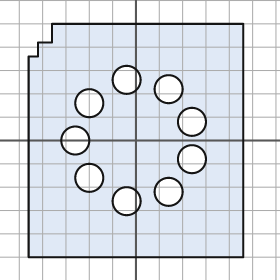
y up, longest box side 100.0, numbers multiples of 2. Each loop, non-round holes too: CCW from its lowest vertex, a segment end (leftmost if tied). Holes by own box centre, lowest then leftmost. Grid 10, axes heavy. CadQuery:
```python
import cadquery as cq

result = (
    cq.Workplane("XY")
    .moveTo(-46.0, -50.0)
    .lineTo(46.0, -50.0)
    .lineTo(46.0, 50.0)
    .lineTo(-36.0, 50.0)
    .lineTo(-36.0, 42.0)
    .lineTo(-42.0, 42.0)
    .lineTo(-42.0, 36.0)
    .lineTo(-46.0, 36.0)
    .close()
    .moveTo(-4.0, -26.0)
    .circle(6.0)
    .moveTo(14.0, -22.0)
    .circle(6.0)
    .moveTo(-20.0, -16.0)
    .circle(6.0)
    .moveTo(24.0, -8.0)
    .circle(6.0)
    .moveTo(-26.0, 0.0)
    .circle(6.0)
    .moveTo(24.0, 8.0)
    .circle(6.0)
    .moveTo(-20.0, 16.0)
    .circle(6.0)
    .moveTo(14.0, 22.0)
    .circle(6.0)
    .moveTo(-4.0, 26.0)
    .circle(6.0)
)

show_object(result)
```